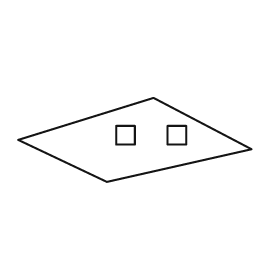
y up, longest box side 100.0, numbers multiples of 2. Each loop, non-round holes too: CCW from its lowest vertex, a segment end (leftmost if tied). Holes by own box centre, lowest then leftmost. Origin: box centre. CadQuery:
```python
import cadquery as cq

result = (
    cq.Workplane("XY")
    .moveTo(-12.0, -18.0)
    .lineTo(50.0, -4.0)
    .lineTo(8.0, 18.0)
    .lineTo(-50.0, 0.0)
    .close()
    .moveTo(-8.0, -2.0)
    .lineTo(0.0, -2.0)
    .lineTo(0.0, 6.0)
    .lineTo(-8.0, 6.0)
    .close()
    .moveTo(14.0, -2.0)
    .lineTo(22.0, -2.0)
    .lineTo(22.0, 6.0)
    .lineTo(14.0, 6.0)
    .close()
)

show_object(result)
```